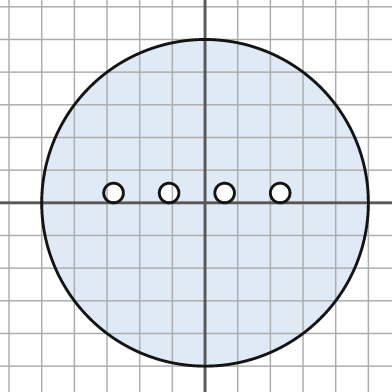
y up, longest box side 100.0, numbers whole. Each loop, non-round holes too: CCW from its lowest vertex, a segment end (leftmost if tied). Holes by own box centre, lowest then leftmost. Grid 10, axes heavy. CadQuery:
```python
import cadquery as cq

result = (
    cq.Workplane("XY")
    .moveTo(0.0, 0.0)
    .circle(50.0)
    .moveTo(-28.0, 3.0)
    .circle(3.0)
    .moveTo(-11.0, 3.0)
    .circle(3.0)
    .moveTo(6.0, 3.0)
    .circle(3.0)
    .moveTo(23.0, 3.0)
    .circle(3.0)
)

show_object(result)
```